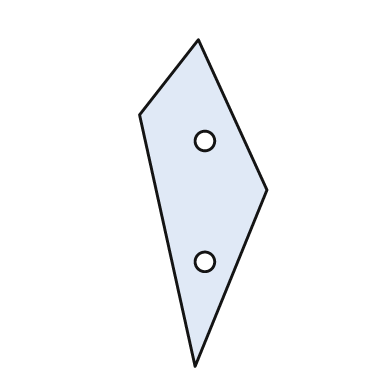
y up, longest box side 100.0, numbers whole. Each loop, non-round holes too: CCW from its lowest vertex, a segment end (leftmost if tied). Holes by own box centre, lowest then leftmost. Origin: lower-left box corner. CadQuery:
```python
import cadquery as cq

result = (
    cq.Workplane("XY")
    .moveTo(17.0, 0.0)
    .lineTo(39.0, 54.0)
    .lineTo(18.0, 100.0)
    .lineTo(0.0, 77.0)
    .close()
    .moveTo(20.0, 32.0)
    .circle(3.0)
    .moveTo(20.0, 69.0)
    .circle(3.0)
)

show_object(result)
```